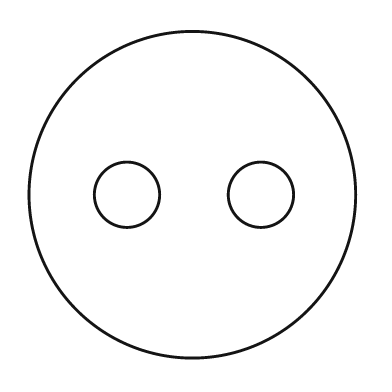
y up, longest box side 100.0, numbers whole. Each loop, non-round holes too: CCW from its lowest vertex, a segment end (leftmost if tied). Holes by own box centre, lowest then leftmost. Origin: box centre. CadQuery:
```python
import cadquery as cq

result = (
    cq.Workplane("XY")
    .moveTo(0.0, 0.0)
    .circle(50.0)
    .moveTo(-20.0, 0.0)
    .circle(10.0)
    .moveTo(21.0, 0.0)
    .circle(10.0)
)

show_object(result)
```